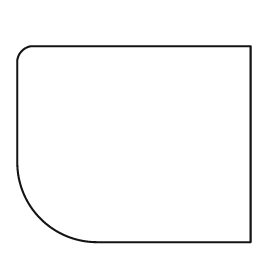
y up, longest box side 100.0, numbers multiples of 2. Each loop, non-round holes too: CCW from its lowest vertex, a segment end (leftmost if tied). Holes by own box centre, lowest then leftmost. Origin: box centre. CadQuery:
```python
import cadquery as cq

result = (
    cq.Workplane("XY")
    .moveTo(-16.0, -42.0)
    .lineTo(50.0, -42.0)
    .lineTo(50.0, 42.0)
    .lineTo(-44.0, 42.0)
    .threePointArc((-48.0, 40.0), (-50.0, 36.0))
    .lineTo(-50.0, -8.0)
    .threePointArc((-40.0, -32.0), (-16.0, -42.0))
    .close()
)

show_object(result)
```